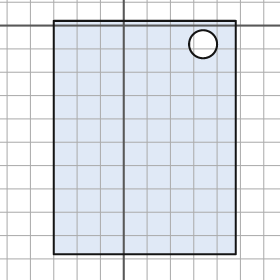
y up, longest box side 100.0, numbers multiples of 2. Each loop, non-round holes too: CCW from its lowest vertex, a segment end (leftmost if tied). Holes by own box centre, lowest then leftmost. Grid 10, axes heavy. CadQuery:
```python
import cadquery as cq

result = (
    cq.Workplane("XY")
    .moveTo(-30.0, -98.0)
    .lineTo(48.0, -98.0)
    .lineTo(48.0, 2.0)
    .lineTo(-30.0, 2.0)
    .close()
    .moveTo(34.0, -8.0)
    .circle(6.0)
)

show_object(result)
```